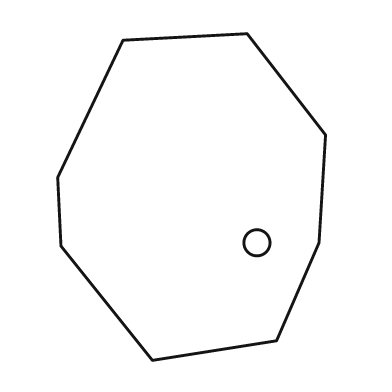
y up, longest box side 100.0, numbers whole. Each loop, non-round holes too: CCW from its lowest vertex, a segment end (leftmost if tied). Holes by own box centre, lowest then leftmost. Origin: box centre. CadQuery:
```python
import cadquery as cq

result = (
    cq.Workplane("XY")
    .moveTo(-12.0, -50.0)
    .lineTo(26.0, -44.0)
    .lineTo(39.0, -14.0)
    .lineTo(41.0, 19.0)
    .lineTo(17.0, 50.0)
    .lineTo(-21.0, 48.0)
    .lineTo(-41.0, 6.0)
    .lineTo(-40.0, -15.0)
    .close()
    .moveTo(20.0, -14.0)
    .circle(4.0)
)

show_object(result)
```